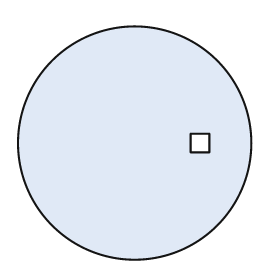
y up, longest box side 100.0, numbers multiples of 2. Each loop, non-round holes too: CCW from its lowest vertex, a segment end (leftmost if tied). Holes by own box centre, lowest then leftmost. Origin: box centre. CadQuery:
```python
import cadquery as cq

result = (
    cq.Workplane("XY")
    .moveTo(0.0, 0.0)
    .circle(50.0)
    .moveTo(24.0, -4.0)
    .lineTo(32.0, -4.0)
    .lineTo(32.0, 4.0)
    .lineTo(24.0, 4.0)
    .close()
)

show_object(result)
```